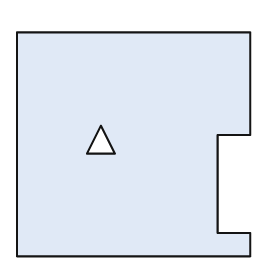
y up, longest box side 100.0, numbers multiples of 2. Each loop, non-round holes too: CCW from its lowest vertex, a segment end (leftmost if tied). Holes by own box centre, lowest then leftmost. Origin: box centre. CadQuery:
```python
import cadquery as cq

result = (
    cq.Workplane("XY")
    .moveTo(-50.0, -48.0)
    .lineTo(50.0, -48.0)
    .lineTo(50.0, -38.0)
    .lineTo(36.0, -38.0)
    .lineTo(36.0, 4.0)
    .lineTo(50.0, 4.0)
    .lineTo(50.0, 48.0)
    .lineTo(-50.0, 48.0)
    .close()
    .moveTo(-20.0, -4.0)
    .lineTo(-8.0, -4.0)
    .lineTo(-14.0, 8.0)
    .close()
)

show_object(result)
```